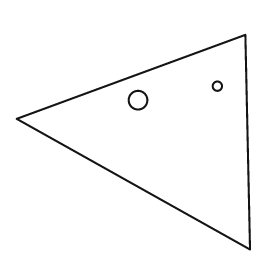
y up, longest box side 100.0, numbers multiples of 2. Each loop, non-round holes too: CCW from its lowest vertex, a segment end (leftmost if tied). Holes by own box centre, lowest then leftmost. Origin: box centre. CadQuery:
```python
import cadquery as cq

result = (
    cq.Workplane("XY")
    .moveTo(50.0, -46.0)
    .lineTo(48.0, 46.0)
    .lineTo(-50.0, 10.0)
    .close()
    .moveTo(2.0, 18.0)
    .circle(4.0)
    .moveTo(36.0, 24.0)
    .circle(2.0)
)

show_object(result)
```